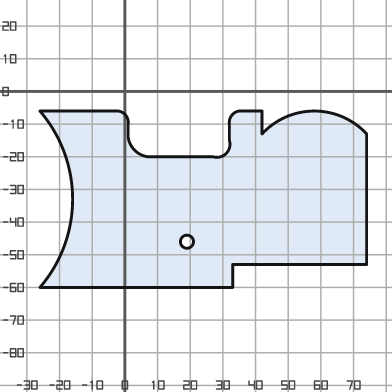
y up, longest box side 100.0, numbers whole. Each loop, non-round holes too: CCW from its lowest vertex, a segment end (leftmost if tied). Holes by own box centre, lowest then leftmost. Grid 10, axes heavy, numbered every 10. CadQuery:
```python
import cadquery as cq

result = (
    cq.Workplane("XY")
    .moveTo(-26.0, -60.0)
    .lineTo(33.0, -60.0)
    .lineTo(33.0, -53.0)
    .lineTo(74.0, -53.0)
    .lineTo(74.0, -13.0)
    .threePointArc((58.0, -6.0), (42.0, -13.0))
    .lineTo(42.0, -6.0)
    .lineTo(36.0, -6.0)
    .threePointArc((33.0, -7.0), (32.0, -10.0))
    .lineTo(32.0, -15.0)
    .threePointArc((31.0, -19.0), (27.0, -20.0))
    .lineTo(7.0, -20.0)
    .threePointArc((3.0, -18.0), (1.0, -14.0))
    .lineTo(1.0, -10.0)
    .threePointArc((0.0, -7.0), (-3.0, -6.0))
    .lineTo(-26.0, -6.0)
    .threePointArc((-16.0, -33.0), (-26.0, -60.0))
    .close()
    .moveTo(19.0, -46.0)
    .circle(2.0)
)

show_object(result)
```